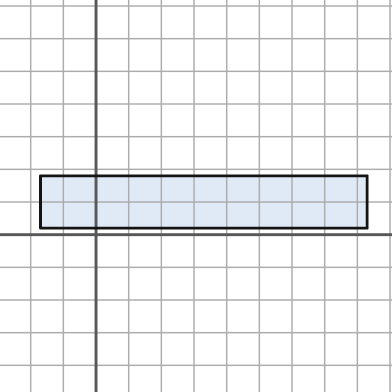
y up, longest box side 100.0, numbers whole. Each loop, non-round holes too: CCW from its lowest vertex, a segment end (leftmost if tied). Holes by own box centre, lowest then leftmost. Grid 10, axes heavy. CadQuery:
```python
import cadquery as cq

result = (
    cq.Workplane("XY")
    .moveTo(-17.0, 2.0)
    .lineTo(83.0, 2.0)
    .lineTo(83.0, 18.0)
    .lineTo(-17.0, 18.0)
    .close()
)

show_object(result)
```